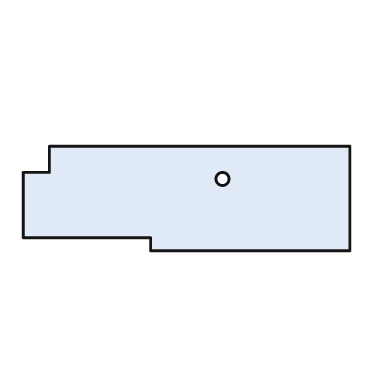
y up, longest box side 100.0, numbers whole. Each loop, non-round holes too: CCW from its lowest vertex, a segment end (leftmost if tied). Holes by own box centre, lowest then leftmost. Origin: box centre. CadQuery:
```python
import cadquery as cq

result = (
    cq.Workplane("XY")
    .moveTo(-11.0, -16.0)
    .lineTo(50.0, -16.0)
    .lineTo(50.0, 16.0)
    .lineTo(-42.0, 16.0)
    .lineTo(-42.0, 8.0)
    .lineTo(-50.0, 8.0)
    .lineTo(-50.0, -12.0)
    .lineTo(-11.0, -12.0)
    .close()
    .moveTo(11.0, 6.0)
    .circle(2.0)
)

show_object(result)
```